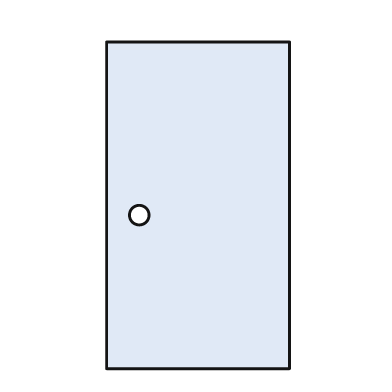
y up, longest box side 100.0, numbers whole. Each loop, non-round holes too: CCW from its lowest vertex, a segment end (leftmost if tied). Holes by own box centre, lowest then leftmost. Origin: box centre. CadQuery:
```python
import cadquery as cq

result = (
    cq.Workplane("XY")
    .moveTo(-28.0, -50.0)
    .lineTo(28.0, -50.0)
    .lineTo(28.0, 50.0)
    .lineTo(-28.0, 50.0)
    .close()
    .moveTo(-18.0, -3.0)
    .circle(3.0)
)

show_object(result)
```